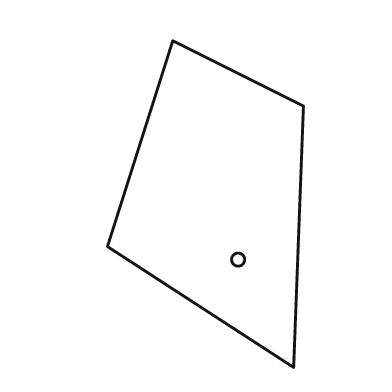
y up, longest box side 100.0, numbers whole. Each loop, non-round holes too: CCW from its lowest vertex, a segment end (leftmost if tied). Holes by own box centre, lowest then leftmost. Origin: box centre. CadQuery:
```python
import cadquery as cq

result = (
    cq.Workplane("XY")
    .moveTo(27.0, -50.0)
    .lineTo(30.0, 30.0)
    .lineTo(-10.0, 50.0)
    .lineTo(-30.0, -13.0)
    .close()
    .moveTo(10.0, -17.0)
    .circle(2.0)
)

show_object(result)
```